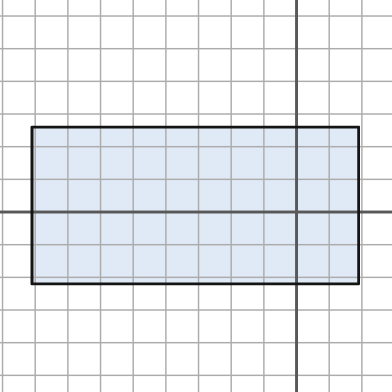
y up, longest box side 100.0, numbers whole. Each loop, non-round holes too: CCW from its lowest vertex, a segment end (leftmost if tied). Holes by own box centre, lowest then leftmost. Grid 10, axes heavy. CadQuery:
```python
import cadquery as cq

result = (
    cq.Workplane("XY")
    .moveTo(-81.0, -22.0)
    .lineTo(19.0, -22.0)
    .lineTo(19.0, 26.0)
    .lineTo(-81.0, 26.0)
    .close()
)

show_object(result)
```